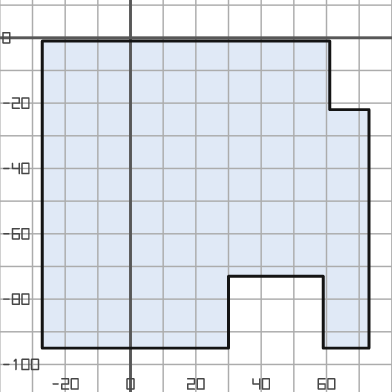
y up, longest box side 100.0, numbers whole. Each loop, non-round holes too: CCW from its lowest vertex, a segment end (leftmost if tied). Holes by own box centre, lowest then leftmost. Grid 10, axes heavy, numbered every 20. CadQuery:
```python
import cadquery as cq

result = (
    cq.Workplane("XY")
    .moveTo(-27.0, -95.0)
    .lineTo(30.0, -95.0)
    .lineTo(30.0, -73.0)
    .lineTo(59.0, -73.0)
    .lineTo(59.0, -95.0)
    .lineTo(73.0, -95.0)
    .lineTo(73.0, -22.0)
    .lineTo(61.0, -22.0)
    .lineTo(61.0, -1.0)
    .lineTo(-27.0, -1.0)
    .close()
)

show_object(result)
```